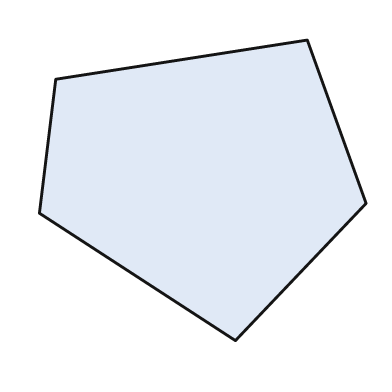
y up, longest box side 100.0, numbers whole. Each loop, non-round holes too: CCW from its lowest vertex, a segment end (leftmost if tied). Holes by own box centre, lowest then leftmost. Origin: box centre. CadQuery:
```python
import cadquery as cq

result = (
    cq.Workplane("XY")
    .moveTo(10.0, -46.0)
    .lineTo(50.0, -4.0)
    .lineTo(32.0, 46.0)
    .lineTo(-45.0, 34.0)
    .lineTo(-50.0, -7.0)
    .close()
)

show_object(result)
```